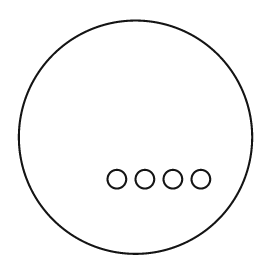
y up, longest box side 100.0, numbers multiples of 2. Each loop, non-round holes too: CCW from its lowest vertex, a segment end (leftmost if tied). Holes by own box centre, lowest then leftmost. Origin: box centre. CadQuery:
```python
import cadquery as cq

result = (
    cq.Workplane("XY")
    .moveTo(0.0, 0.0)
    .circle(50.0)
    .moveTo(-8.0, -18.0)
    .circle(4.0)
    .moveTo(4.0, -18.0)
    .circle(4.0)
    .moveTo(16.0, -18.0)
    .circle(4.0)
    .moveTo(28.0, -18.0)
    .circle(4.0)
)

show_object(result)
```